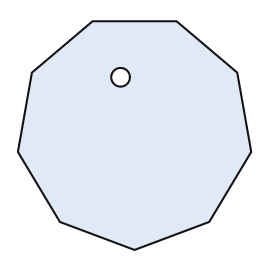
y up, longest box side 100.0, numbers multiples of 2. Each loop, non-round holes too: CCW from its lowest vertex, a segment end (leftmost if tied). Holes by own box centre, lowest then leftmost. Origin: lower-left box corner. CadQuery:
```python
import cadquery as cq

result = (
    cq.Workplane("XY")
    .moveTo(50.0, 0.0)
    .lineTo(82.0, 12.0)
    .lineTo(100.0, 42.0)
    .lineTo(94.0, 76.0)
    .lineTo(68.0, 98.0)
    .lineTo(32.0, 98.0)
    .lineTo(6.0, 76.0)
    .lineTo(0.0, 42.0)
    .lineTo(18.0, 12.0)
    .close()
    .moveTo(44.0, 74.0)
    .circle(4.0)
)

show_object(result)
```